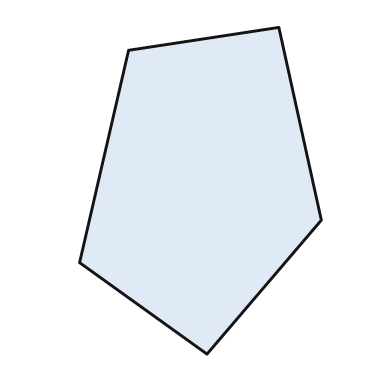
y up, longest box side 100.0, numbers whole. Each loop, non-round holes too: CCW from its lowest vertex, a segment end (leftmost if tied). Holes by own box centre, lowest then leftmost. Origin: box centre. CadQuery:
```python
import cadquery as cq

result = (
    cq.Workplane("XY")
    .moveTo(2.0, -50.0)
    .lineTo(37.0, -9.0)
    .lineTo(24.0, 50.0)
    .lineTo(-22.0, 43.0)
    .lineTo(-37.0, -22.0)
    .close()
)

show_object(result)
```